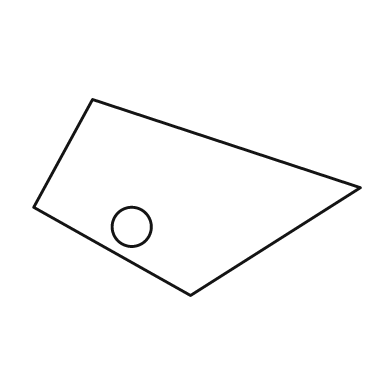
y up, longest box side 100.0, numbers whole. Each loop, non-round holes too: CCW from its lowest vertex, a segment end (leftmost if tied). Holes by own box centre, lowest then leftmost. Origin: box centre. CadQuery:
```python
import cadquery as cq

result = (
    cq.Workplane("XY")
    .moveTo(-2.0, -30.0)
    .lineTo(50.0, 3.0)
    .lineTo(-32.0, 30.0)
    .lineTo(-50.0, -3.0)
    .close()
    .moveTo(-20.0, -9.0)
    .circle(6.0)
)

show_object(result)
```